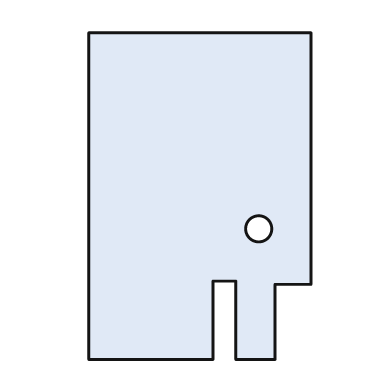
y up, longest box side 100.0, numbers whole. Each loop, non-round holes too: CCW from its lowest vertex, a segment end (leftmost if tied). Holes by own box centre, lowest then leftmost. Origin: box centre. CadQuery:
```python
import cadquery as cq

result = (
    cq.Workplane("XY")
    .moveTo(-34.0, -50.0)
    .lineTo(4.0, -50.0)
    .lineTo(4.0, -26.0)
    .lineTo(11.0, -26.0)
    .lineTo(11.0, -50.0)
    .lineTo(23.0, -50.0)
    .lineTo(23.0, -27.0)
    .lineTo(34.0, -27.0)
    .lineTo(34.0, 50.0)
    .lineTo(-34.0, 50.0)
    .close()
    .moveTo(18.0, -10.0)
    .circle(4.0)
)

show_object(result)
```